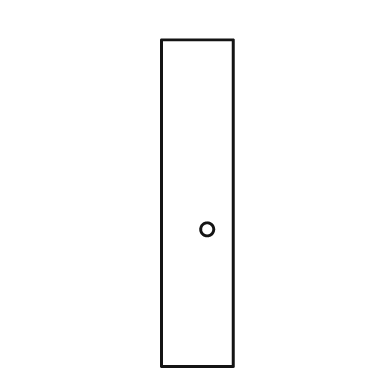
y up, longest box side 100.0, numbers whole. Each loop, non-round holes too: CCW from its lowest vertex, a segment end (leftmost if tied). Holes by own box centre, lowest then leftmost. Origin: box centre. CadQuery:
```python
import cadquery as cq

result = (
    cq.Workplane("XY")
    .moveTo(-11.0, -50.0)
    .lineTo(11.0, -50.0)
    .lineTo(11.0, 50.0)
    .lineTo(-11.0, 50.0)
    .close()
    .moveTo(3.0, -8.0)
    .circle(2.0)
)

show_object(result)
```